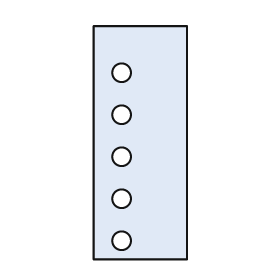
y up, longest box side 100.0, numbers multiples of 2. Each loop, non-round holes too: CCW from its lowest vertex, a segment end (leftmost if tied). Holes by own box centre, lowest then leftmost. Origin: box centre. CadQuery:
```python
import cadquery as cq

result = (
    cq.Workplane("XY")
    .moveTo(-20.0, -50.0)
    .lineTo(20.0, -50.0)
    .lineTo(20.0, 50.0)
    .lineTo(-20.0, 50.0)
    .close()
    .moveTo(-8.0, -42.0)
    .circle(4.0)
    .moveTo(-8.0, -24.0)
    .circle(4.0)
    .moveTo(-8.0, -6.0)
    .circle(4.0)
    .moveTo(-8.0, 12.0)
    .circle(4.0)
    .moveTo(-8.0, 30.0)
    .circle(4.0)
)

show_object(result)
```